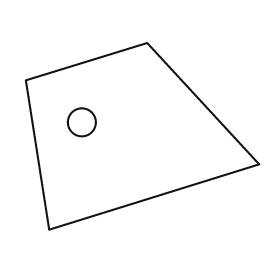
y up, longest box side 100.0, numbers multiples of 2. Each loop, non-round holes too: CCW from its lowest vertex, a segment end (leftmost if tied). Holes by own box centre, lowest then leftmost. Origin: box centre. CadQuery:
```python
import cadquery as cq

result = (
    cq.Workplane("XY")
    .moveTo(-40.0, -40.0)
    .lineTo(50.0, -12.0)
    .lineTo(2.0, 40.0)
    .lineTo(-50.0, 24.0)
    .close()
    .moveTo(-26.0, 6.0)
    .circle(6.0)
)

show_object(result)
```